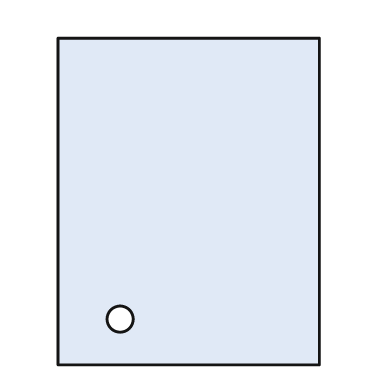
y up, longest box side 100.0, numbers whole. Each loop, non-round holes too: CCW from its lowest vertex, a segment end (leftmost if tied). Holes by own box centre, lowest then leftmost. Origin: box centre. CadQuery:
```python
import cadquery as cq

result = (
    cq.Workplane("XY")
    .moveTo(-40.0, -50.0)
    .lineTo(40.0, -50.0)
    .lineTo(40.0, 50.0)
    .lineTo(-40.0, 50.0)
    .close()
    .moveTo(-21.0, -36.0)
    .circle(4.0)
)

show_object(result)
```